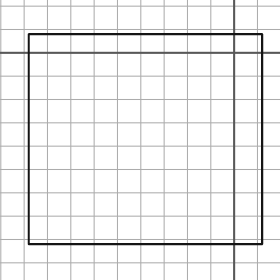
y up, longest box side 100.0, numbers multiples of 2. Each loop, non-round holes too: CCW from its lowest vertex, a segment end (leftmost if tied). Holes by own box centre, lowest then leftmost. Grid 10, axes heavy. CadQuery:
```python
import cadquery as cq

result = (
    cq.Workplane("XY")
    .moveTo(-88.0, -82.0)
    .lineTo(12.0, -82.0)
    .lineTo(12.0, 8.0)
    .lineTo(-88.0, 8.0)
    .close()
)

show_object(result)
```